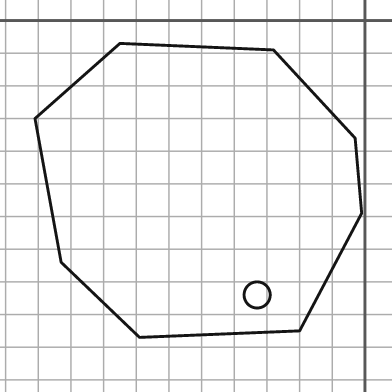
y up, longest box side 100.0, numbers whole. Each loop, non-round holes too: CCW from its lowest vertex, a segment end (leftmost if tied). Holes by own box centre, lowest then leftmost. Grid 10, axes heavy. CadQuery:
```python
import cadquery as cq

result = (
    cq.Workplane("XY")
    .moveTo(-69.0, -97.0)
    .lineTo(-20.0, -95.0)
    .lineTo(-1.0, -59.0)
    .lineTo(-3.0, -36.0)
    .lineTo(-28.0, -9.0)
    .lineTo(-75.0, -7.0)
    .lineTo(-101.0, -30.0)
    .lineTo(-93.0, -74.0)
    .close()
    .moveTo(-33.0, -84.0)
    .circle(4.0)
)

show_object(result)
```